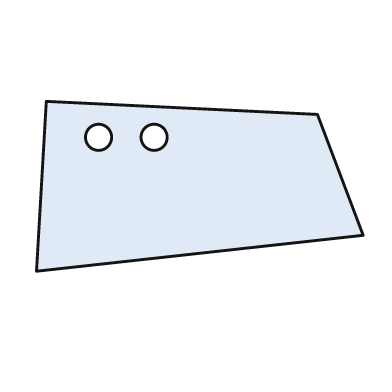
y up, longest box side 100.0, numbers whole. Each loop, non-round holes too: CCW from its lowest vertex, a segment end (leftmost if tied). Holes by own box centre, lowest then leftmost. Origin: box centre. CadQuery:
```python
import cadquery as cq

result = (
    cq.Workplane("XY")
    .moveTo(-50.0, -26.0)
    .lineTo(50.0, -15.0)
    .lineTo(36.0, 22.0)
    .lineTo(-47.0, 26.0)
    .close()
    .moveTo(-31.0, 15.0)
    .circle(4.0)
    .moveTo(-14.0, 15.0)
    .circle(4.0)
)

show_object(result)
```